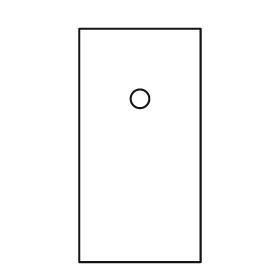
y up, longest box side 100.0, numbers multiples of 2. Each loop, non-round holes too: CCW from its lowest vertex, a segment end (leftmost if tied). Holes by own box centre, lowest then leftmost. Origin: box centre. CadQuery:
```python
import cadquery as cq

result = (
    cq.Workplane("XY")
    .moveTo(-26.0, -50.0)
    .lineTo(26.0, -50.0)
    .lineTo(26.0, 50.0)
    .lineTo(-26.0, 50.0)
    .close()
    .moveTo(0.0, 20.0)
    .circle(4.0)
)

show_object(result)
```